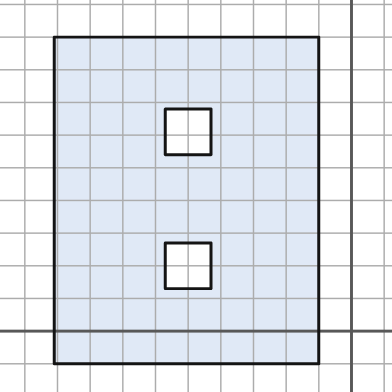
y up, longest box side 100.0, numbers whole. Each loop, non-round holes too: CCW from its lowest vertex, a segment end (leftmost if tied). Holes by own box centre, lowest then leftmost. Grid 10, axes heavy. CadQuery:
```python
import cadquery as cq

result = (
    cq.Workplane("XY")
    .moveTo(-91.0, -10.0)
    .lineTo(-10.0, -10.0)
    .lineTo(-10.0, 90.0)
    .lineTo(-91.0, 90.0)
    .close()
    .moveTo(-57.0, 13.0)
    .lineTo(-43.0, 13.0)
    .lineTo(-43.0, 27.0)
    .lineTo(-57.0, 27.0)
    .close()
    .moveTo(-57.0, 54.0)
    .lineTo(-43.0, 54.0)
    .lineTo(-43.0, 68.0)
    .lineTo(-57.0, 68.0)
    .close()
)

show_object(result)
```